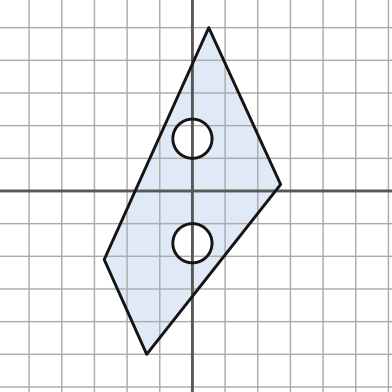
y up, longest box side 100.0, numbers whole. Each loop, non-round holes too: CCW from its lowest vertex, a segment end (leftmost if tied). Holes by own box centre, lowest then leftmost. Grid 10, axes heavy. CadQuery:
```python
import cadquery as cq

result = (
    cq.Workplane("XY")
    .moveTo(-14.0, -50.0)
    .lineTo(27.0, 2.0)
    .lineTo(5.0, 50.0)
    .lineTo(-27.0, -21.0)
    .close()
    .moveTo(0.0, -16.0)
    .circle(6.0)
    .moveTo(0.0, 16.0)
    .circle(6.0)
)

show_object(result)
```